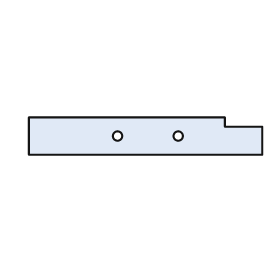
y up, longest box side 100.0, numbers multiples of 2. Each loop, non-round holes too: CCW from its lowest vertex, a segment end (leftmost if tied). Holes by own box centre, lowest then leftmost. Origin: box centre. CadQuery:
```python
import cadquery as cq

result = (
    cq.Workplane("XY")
    .moveTo(-50.0, -8.0)
    .lineTo(50.0, -8.0)
    .lineTo(50.0, 4.0)
    .lineTo(34.0, 4.0)
    .lineTo(34.0, 8.0)
    .lineTo(-50.0, 8.0)
    .close()
    .moveTo(-12.0, 0.0)
    .circle(2.0)
    .moveTo(14.0, 0.0)
    .circle(2.0)
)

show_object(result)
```